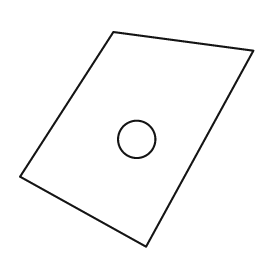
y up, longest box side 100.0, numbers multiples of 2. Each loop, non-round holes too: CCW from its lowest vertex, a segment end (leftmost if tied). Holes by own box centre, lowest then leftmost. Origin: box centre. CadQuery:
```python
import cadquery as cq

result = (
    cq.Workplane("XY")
    .moveTo(4.0, -46.0)
    .lineTo(50.0, 38.0)
    .lineTo(-10.0, 46.0)
    .lineTo(-50.0, -16.0)
    .close()
    .moveTo(0.0, 0.0)
    .circle(8.0)
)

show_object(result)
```